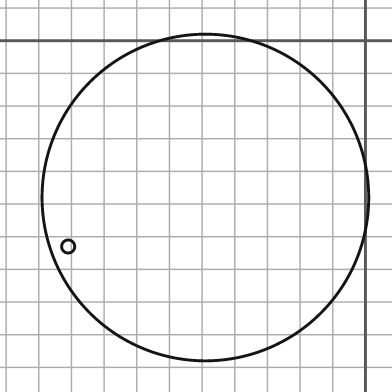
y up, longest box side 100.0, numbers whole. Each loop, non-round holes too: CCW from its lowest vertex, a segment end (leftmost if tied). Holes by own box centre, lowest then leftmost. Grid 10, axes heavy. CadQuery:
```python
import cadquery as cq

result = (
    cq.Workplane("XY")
    .moveTo(-49.0, -48.0)
    .circle(50.0)
    .moveTo(-91.0, -63.0)
    .circle(2.0)
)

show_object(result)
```